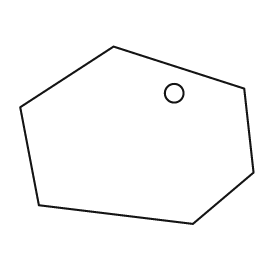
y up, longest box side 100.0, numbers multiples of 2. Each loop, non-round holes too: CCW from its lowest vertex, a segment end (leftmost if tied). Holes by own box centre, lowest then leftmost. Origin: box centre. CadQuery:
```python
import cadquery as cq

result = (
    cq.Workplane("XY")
    .moveTo(24.0, -38.0)
    .lineTo(50.0, -16.0)
    .lineTo(46.0, 20.0)
    .lineTo(-10.0, 38.0)
    .lineTo(-50.0, 12.0)
    .lineTo(-42.0, -30.0)
    .close()
    .moveTo(16.0, 18.0)
    .circle(4.0)
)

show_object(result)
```